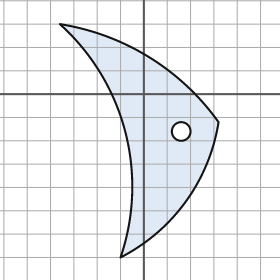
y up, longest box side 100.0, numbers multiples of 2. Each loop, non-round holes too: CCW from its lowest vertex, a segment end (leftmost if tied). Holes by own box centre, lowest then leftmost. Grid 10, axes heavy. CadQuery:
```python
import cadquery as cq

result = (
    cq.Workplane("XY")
    .moveTo(-10.0, -70.0)
    .threePointArc((18.0, -46.0), (32.0, -12.0))
    .threePointArc((2.0, 16.0), (-36.0, 30.0))
    .threePointArc((-8.0, -16.0), (-10.0, -70.0))
    .close()
    .moveTo(16.0, -16.0)
    .circle(4.0)
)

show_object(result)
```